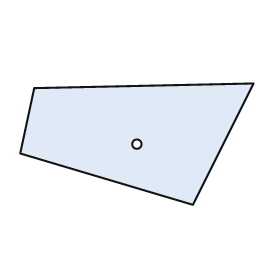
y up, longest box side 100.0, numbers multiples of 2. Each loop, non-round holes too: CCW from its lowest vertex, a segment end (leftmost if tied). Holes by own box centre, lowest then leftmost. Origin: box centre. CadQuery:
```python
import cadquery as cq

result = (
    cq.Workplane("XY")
    .moveTo(24.0, -26.0)
    .lineTo(50.0, 26.0)
    .lineTo(-44.0, 24.0)
    .lineTo(-50.0, -4.0)
    .close()
    .moveTo(0.0, 0.0)
    .circle(2.0)
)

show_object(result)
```